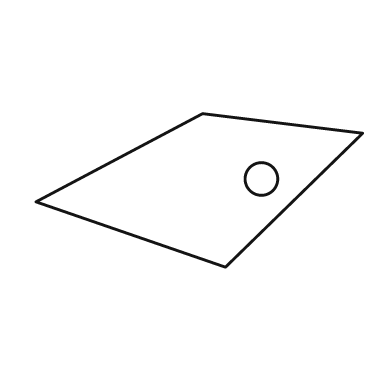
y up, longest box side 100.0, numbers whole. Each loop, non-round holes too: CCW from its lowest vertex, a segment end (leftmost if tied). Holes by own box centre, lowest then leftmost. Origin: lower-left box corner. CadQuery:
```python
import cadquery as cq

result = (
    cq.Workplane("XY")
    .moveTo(58.0, 0.0)
    .lineTo(100.0, 41.0)
    .lineTo(51.0, 47.0)
    .lineTo(0.0, 20.0)
    .close()
    .moveTo(69.0, 27.0)
    .circle(5.0)
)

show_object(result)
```